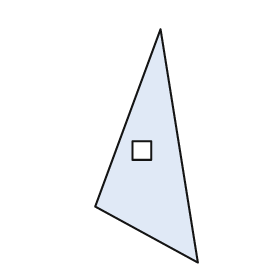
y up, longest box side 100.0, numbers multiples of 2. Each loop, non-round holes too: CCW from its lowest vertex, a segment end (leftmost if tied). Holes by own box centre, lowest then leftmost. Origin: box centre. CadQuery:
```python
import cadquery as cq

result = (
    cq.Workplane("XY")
    .moveTo(22.0, -50.0)
    .lineTo(6.0, 50.0)
    .lineTo(-22.0, -26.0)
    .close()
    .moveTo(-6.0, -6.0)
    .lineTo(2.0, -6.0)
    .lineTo(2.0, 2.0)
    .lineTo(-6.0, 2.0)
    .close()
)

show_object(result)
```